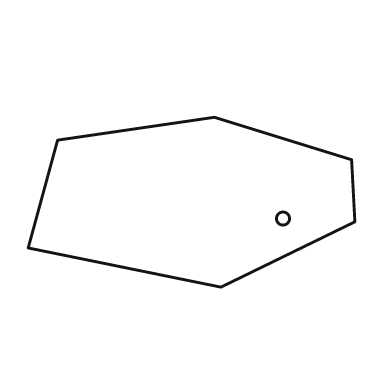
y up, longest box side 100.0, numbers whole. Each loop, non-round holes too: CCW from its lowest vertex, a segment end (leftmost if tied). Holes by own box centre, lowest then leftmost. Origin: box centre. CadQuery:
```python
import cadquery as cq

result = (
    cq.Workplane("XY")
    .moveTo(9.0, -26.0)
    .lineTo(50.0, -6.0)
    .lineTo(49.0, 13.0)
    .lineTo(7.0, 26.0)
    .lineTo(-41.0, 19.0)
    .lineTo(-50.0, -14.0)
    .close()
    .moveTo(28.0, -5.0)
    .circle(2.0)
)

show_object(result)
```